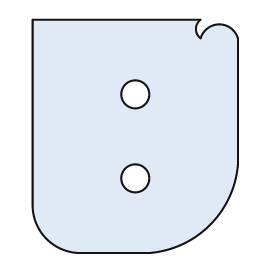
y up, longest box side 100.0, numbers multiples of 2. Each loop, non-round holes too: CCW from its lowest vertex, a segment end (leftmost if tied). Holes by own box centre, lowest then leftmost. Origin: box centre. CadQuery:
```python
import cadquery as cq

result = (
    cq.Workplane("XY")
    .moveTo(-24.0, -50.0)
    .lineTo(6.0, -50.0)
    .threePointArc((32.0, -38.0), (44.0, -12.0))
    .lineTo(44.0, 42.0)
    .threePointArc((36.0, 48.0), (28.0, 42.0))
    .threePointArc((26.0, 46.0), (28.0, 50.0))
    .lineTo(-44.0, 50.0)
    .lineTo(-44.0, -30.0)
    .threePointArc((-38.0, -44.0), (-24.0, -50.0))
    .close()
    .moveTo(0.0, -18.0)
    .circle(6.0)
    .moveTo(0.0, 18.0)
    .circle(6.0)
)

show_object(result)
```